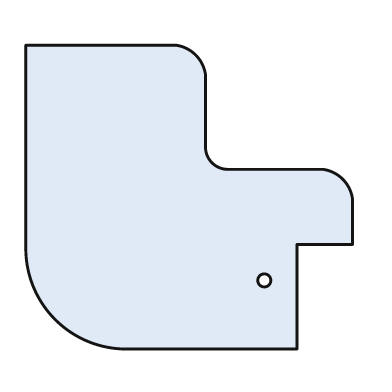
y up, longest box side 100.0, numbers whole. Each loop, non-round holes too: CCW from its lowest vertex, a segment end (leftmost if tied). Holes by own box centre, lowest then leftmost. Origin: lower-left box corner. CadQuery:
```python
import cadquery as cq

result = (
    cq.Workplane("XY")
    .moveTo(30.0, 0.0)
    .lineTo(83.0, 0.0)
    .lineTo(83.0, 32.0)
    .lineTo(100.0, 32.0)
    .lineTo(100.0, 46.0)
    .threePointArc((97.0, 52.0), (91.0, 55.0))
    .lineTo(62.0, 55.0)
    .threePointArc((57.0, 57.0), (55.0, 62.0))
    .lineTo(55.0, 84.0)
    .threePointArc((52.0, 90.0), (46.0, 93.0))
    .lineTo(0.0, 93.0)
    .lineTo(0.0, 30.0)
    .threePointArc((9.0, 9.0), (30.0, 0.0))
    .close()
    .moveTo(73.0, 21.0)
    .circle(2.0)
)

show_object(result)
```